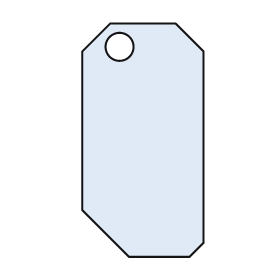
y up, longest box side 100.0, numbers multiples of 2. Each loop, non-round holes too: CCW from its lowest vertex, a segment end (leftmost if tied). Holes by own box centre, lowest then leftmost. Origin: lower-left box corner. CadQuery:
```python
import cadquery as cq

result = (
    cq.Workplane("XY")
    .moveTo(20.0, 0.0)
    .lineTo(46.0, 0.0)
    .lineTo(52.0, 6.0)
    .lineTo(52.0, 88.0)
    .lineTo(40.0, 100.0)
    .lineTo(12.0, 100.0)
    .lineTo(0.0, 88.0)
    .lineTo(0.0, 20.0)
    .close()
    .moveTo(16.0, 90.0)
    .circle(6.0)
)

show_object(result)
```